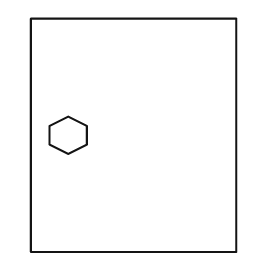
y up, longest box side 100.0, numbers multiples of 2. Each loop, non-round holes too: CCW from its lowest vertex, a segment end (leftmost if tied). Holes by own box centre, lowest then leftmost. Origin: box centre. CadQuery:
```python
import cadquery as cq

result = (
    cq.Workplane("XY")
    .moveTo(-44.0, -50.0)
    .lineTo(44.0, -50.0)
    .lineTo(44.0, 50.0)
    .lineTo(-44.0, 50.0)
    .close()
    .moveTo(-28.0, -8.0)
    .lineTo(-20.0, -4.0)
    .lineTo(-20.0, 4.0)
    .lineTo(-28.0, 8.0)
    .lineTo(-36.0, 4.0)
    .lineTo(-36.0, -4.0)
    .close()
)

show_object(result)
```